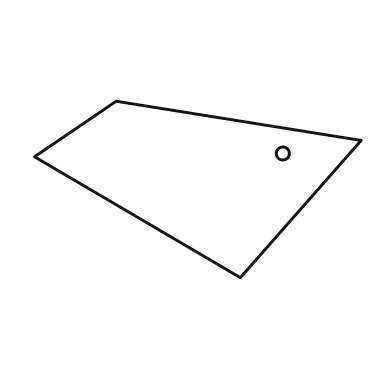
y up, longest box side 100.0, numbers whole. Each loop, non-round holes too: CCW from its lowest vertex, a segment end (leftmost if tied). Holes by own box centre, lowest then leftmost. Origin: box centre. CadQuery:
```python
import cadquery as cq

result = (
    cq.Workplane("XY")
    .moveTo(13.0, -27.0)
    .lineTo(50.0, 15.0)
    .lineTo(-25.0, 27.0)
    .lineTo(-50.0, 10.0)
    .close()
    .moveTo(26.0, 11.0)
    .circle(2.0)
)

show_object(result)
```